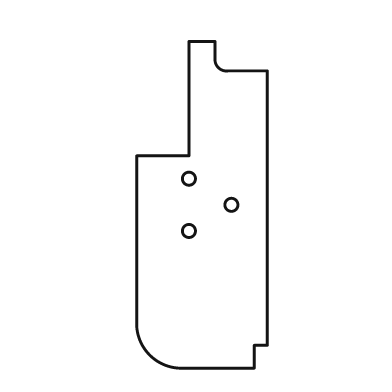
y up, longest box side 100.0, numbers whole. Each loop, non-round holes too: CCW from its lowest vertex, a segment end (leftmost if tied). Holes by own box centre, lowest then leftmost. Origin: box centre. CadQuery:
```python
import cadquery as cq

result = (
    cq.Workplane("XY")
    .moveTo(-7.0, -50.0)
    .lineTo(16.0, -50.0)
    .lineTo(16.0, -43.0)
    .lineTo(20.0, -43.0)
    .lineTo(20.0, 41.0)
    .lineTo(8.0, 41.0)
    .threePointArc((5.0, 42.0), (4.0, 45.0))
    .lineTo(4.0, 50.0)
    .lineTo(-4.0, 50.0)
    .lineTo(-4.0, 15.0)
    .lineTo(-20.0, 15.0)
    .lineTo(-20.0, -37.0)
    .threePointArc((-16.0, -46.0), (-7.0, -50.0))
    .close()
    .moveTo(-4.0, -8.0)
    .circle(2.0)
    .moveTo(9.0, 0.0)
    .circle(2.0)
    .moveTo(-4.0, 8.0)
    .circle(2.0)
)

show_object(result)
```